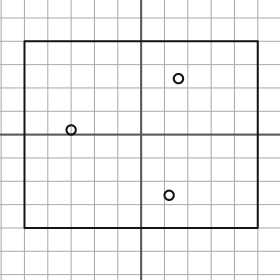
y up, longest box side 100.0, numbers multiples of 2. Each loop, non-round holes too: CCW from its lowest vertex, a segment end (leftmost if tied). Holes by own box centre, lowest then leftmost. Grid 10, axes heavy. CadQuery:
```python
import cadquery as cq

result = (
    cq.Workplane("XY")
    .moveTo(-50.0, -40.0)
    .lineTo(50.0, -40.0)
    .lineTo(50.0, 40.0)
    .lineTo(-50.0, 40.0)
    .close()
    .moveTo(12.0, -26.0)
    .circle(2.0)
    .moveTo(-30.0, 2.0)
    .circle(2.0)
    .moveTo(16.0, 24.0)
    .circle(2.0)
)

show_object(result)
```